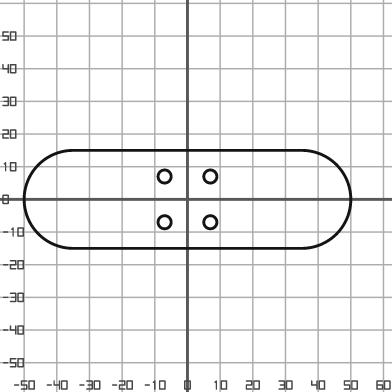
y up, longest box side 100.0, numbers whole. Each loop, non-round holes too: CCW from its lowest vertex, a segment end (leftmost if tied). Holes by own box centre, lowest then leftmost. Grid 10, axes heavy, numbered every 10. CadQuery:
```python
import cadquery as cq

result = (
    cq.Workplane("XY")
    .moveTo(-35.0, -15.0)
    .lineTo(35.0, -15.0)
    .threePointArc((50.0, 0.0), (35.0, 15.0))
    .lineTo(-35.0, 15.0)
    .threePointArc((-50.0, 0.0), (-35.0, -15.0))
    .close()
    .moveTo(-7.0, -7.0)
    .circle(2.0)
    .moveTo(7.0, -7.0)
    .circle(2.0)
    .moveTo(-7.0, 7.0)
    .circle(2.0)
    .moveTo(7.0, 7.0)
    .circle(2.0)
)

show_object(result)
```